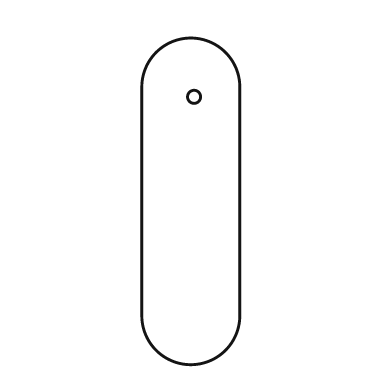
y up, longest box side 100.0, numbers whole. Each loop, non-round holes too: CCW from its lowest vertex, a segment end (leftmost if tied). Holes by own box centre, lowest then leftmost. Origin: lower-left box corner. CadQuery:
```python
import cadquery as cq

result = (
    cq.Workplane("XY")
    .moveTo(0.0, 15.0)
    .threePointArc((15.0, 0.0), (30.0, 15.0))
    .lineTo(30.0, 85.0)
    .threePointArc((15.0, 100.0), (0.0, 85.0))
    .close()
    .moveTo(16.0, 82.0)
    .circle(2.0)
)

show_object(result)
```